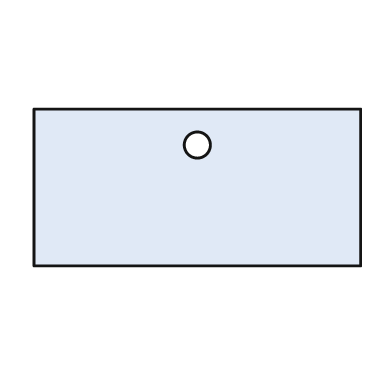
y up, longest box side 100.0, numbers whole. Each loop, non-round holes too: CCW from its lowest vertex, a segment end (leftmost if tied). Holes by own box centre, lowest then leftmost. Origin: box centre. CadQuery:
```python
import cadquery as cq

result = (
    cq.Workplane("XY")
    .moveTo(-50.0, -24.0)
    .lineTo(50.0, -24.0)
    .lineTo(50.0, 24.0)
    .lineTo(-50.0, 24.0)
    .close()
    .moveTo(0.0, 13.0)
    .circle(4.0)
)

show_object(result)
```